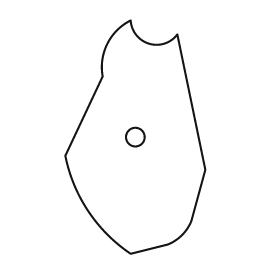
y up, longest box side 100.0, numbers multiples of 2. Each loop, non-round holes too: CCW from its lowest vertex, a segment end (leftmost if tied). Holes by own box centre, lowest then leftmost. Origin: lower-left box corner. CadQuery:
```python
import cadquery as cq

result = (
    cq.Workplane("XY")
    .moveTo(28.0, 0.0)
    .lineTo(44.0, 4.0)
    .threePointArc((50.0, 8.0), (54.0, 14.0))
    .lineTo(60.0, 36.0)
    .lineTo(48.0, 94.0)
    .threePointArc((36.0, 90.0), (28.0, 100.0))
    .threePointArc((18.0, 90.0), (16.0, 76.0))
    .lineTo(0.0, 42.0)
    .threePointArc((10.0, 18.0), (28.0, 0.0))
    .close()
    .moveTo(30.0, 50.0)
    .circle(4.0)
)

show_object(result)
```